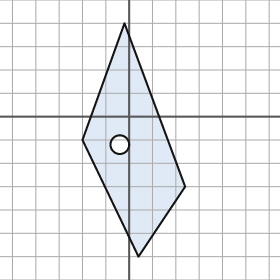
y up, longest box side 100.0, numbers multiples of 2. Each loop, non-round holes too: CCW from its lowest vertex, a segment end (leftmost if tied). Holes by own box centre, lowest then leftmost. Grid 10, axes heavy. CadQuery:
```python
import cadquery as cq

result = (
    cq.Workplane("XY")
    .moveTo(4.0, -60.0)
    .lineTo(24.0, -30.0)
    .lineTo(-2.0, 40.0)
    .lineTo(-20.0, -10.0)
    .close()
    .moveTo(-4.0, -12.0)
    .circle(4.0)
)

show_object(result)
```